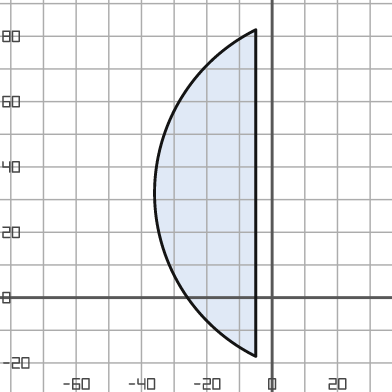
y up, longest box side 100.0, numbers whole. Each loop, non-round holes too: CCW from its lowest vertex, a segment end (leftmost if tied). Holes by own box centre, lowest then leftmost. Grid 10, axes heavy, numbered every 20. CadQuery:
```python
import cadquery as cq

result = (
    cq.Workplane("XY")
    .moveTo(-5.0, -18.0)
    .lineTo(-5.0, 82.0)
    .threePointArc((-36.0, 32.0), (-5.0, -18.0))
    .close()
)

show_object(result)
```